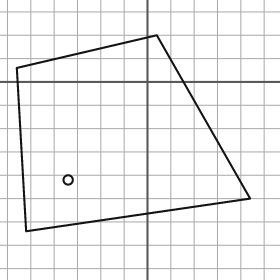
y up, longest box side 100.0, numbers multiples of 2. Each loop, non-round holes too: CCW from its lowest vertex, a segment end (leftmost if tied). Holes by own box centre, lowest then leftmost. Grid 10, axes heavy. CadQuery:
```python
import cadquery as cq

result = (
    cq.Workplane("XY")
    .moveTo(-52.0, -64.0)
    .lineTo(44.0, -50.0)
    .lineTo(4.0, 20.0)
    .lineTo(-56.0, 6.0)
    .close()
    .moveTo(-34.0, -42.0)
    .circle(2.0)
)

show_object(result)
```